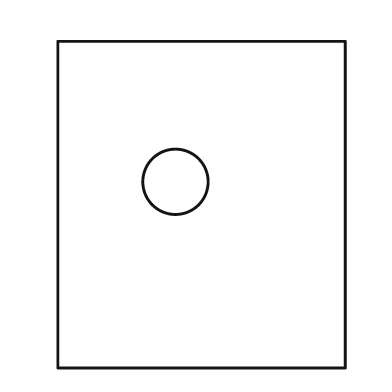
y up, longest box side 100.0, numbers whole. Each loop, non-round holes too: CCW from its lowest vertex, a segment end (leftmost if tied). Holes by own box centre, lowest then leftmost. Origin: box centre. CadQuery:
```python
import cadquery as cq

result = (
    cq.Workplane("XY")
    .moveTo(-44.0, -50.0)
    .lineTo(44.0, -50.0)
    .lineTo(44.0, 50.0)
    .lineTo(-44.0, 50.0)
    .close()
    .moveTo(-8.0, 7.0)
    .circle(10.0)
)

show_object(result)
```